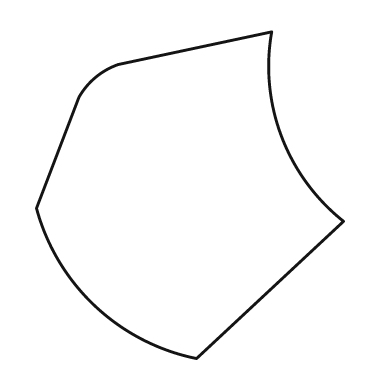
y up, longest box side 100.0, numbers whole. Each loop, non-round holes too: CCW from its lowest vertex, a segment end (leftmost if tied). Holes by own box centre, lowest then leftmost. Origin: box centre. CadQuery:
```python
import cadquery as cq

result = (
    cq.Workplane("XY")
    .moveTo(2.0, -50.0)
    .lineTo(47.0, -8.0)
    .threePointArc((28.0, 18.0), (25.0, 50.0))
    .lineTo(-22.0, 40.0)
    .threePointArc((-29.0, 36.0), (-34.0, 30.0))
    .lineTo(-47.0, -4.0)
    .threePointArc((-29.0, -34.0), (2.0, -50.0))
    .close()
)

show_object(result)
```